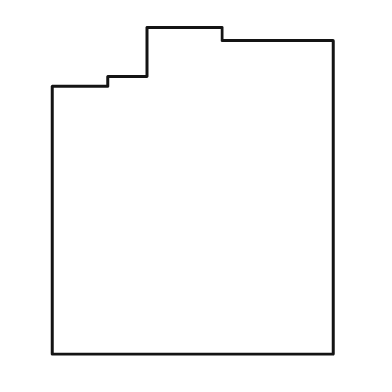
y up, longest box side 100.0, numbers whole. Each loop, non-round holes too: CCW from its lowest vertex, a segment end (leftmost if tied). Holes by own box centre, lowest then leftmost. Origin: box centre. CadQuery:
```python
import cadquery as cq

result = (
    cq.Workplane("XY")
    .moveTo(-43.0, -50.0)
    .lineTo(43.0, -50.0)
    .lineTo(43.0, 46.0)
    .lineTo(9.0, 46.0)
    .lineTo(9.0, 50.0)
    .lineTo(-14.0, 50.0)
    .lineTo(-14.0, 35.0)
    .lineTo(-26.0, 35.0)
    .lineTo(-26.0, 32.0)
    .lineTo(-43.0, 32.0)
    .close()
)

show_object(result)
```